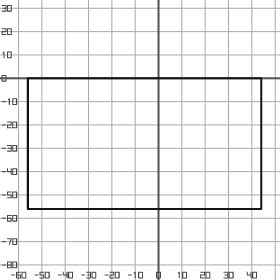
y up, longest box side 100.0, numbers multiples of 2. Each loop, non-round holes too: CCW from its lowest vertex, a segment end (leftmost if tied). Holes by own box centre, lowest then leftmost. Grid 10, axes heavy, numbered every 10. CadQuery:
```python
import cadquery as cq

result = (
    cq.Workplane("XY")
    .moveTo(-56.0, -56.0)
    .lineTo(44.0, -56.0)
    .lineTo(44.0, 0.0)
    .lineTo(-56.0, 0.0)
    .close()
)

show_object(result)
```